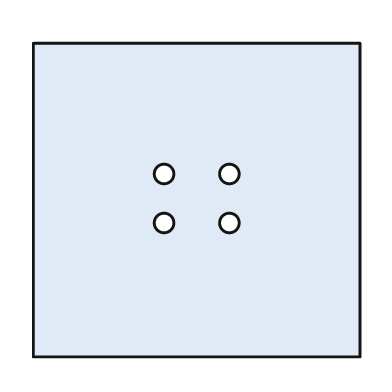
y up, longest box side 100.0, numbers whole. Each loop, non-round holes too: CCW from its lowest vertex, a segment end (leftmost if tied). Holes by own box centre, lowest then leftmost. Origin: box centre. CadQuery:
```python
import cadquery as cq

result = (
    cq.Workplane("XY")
    .moveTo(-50.0, -48.0)
    .lineTo(50.0, -48.0)
    .lineTo(50.0, 48.0)
    .lineTo(-50.0, 48.0)
    .close()
    .moveTo(-10.0, -7.0)
    .circle(3.0)
    .moveTo(10.0, -7.0)
    .circle(3.0)
    .moveTo(-10.0, 8.0)
    .circle(3.0)
    .moveTo(10.0, 8.0)
    .circle(3.0)
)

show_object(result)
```